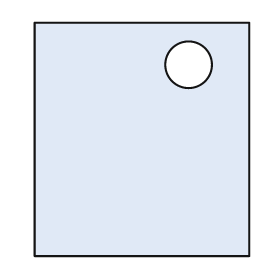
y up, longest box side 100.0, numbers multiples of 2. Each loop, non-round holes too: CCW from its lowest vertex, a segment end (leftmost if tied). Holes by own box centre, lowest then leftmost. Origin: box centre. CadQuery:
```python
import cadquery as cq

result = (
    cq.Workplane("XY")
    .moveTo(-46.0, -50.0)
    .lineTo(46.0, -50.0)
    .lineTo(46.0, 50.0)
    .lineTo(-46.0, 50.0)
    .close()
    .moveTo(20.0, 32.0)
    .circle(10.0)
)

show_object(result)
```